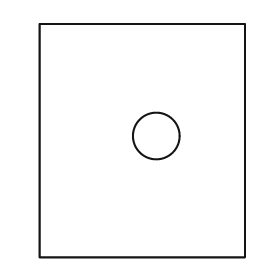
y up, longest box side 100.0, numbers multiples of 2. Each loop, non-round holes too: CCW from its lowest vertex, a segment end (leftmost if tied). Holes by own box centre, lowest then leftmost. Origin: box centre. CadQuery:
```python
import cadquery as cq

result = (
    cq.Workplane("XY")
    .moveTo(-44.0, -50.0)
    .lineTo(44.0, -50.0)
    .lineTo(44.0, 50.0)
    .lineTo(-44.0, 50.0)
    .close()
    .moveTo(6.0, 2.0)
    .circle(10.0)
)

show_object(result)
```